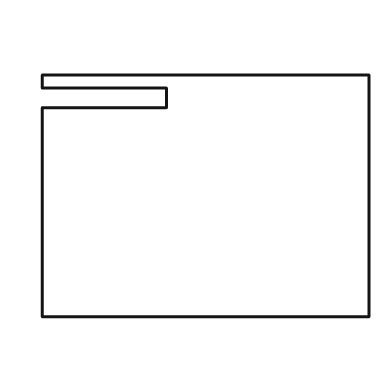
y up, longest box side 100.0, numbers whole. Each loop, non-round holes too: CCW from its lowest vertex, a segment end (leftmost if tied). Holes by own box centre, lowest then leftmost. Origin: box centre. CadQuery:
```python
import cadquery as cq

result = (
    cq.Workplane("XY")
    .moveTo(-50.0, -37.0)
    .lineTo(50.0, -37.0)
    .lineTo(50.0, 37.0)
    .lineTo(-50.0, 37.0)
    .lineTo(-50.0, 33.0)
    .lineTo(-12.0, 33.0)
    .lineTo(-12.0, 27.0)
    .lineTo(-50.0, 27.0)
    .close()
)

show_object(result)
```